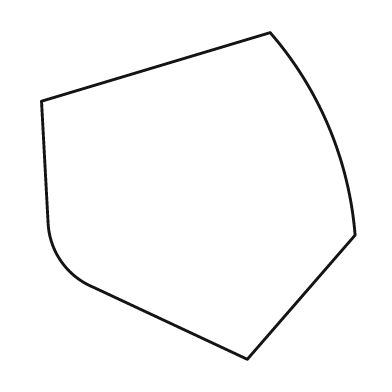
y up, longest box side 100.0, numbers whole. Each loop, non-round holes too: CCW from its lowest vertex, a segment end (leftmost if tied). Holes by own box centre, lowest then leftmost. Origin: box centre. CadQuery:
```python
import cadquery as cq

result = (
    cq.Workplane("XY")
    .moveTo(15.0, -50.0)
    .lineTo(48.0, -12.0)
    .threePointArc((40.0, 21.0), (22.0, 50.0))
    .lineTo(-48.0, 29.0)
    .lineTo(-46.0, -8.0)
    .threePointArc((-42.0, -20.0), (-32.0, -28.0))
    .close()
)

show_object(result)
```